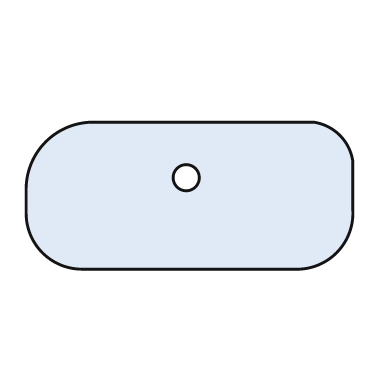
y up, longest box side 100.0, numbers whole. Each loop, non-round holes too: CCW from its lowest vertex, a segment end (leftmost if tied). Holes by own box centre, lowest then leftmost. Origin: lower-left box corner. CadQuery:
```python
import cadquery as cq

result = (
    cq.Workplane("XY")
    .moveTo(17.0, 0.0)
    .lineTo(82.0, 0.0)
    .threePointArc((95.0, 5.0), (100.0, 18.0))
    .lineTo(100.0, 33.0)
    .threePointArc((96.0, 41.0), (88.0, 45.0))
    .lineTo(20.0, 45.0)
    .threePointArc((6.0, 39.0), (0.0, 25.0))
    .lineTo(0.0, 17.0)
    .threePointArc((5.0, 5.0), (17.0, 0.0))
    .close()
    .moveTo(49.0, 28.0)
    .circle(4.0)
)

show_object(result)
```